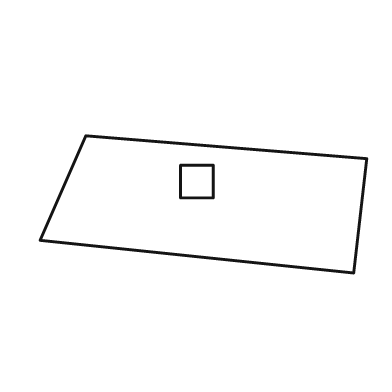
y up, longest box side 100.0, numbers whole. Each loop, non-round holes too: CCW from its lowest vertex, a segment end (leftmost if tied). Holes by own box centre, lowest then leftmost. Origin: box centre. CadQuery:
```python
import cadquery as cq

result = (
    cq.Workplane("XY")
    .moveTo(46.0, -21.0)
    .lineTo(50.0, 14.0)
    .lineTo(-36.0, 21.0)
    .lineTo(-50.0, -11.0)
    .close()
    .moveTo(-7.0, 2.0)
    .lineTo(3.0, 2.0)
    .lineTo(3.0, 12.0)
    .lineTo(-7.0, 12.0)
    .close()
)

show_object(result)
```